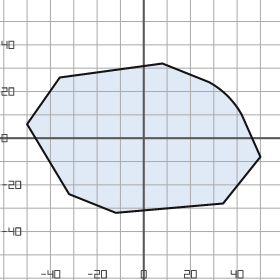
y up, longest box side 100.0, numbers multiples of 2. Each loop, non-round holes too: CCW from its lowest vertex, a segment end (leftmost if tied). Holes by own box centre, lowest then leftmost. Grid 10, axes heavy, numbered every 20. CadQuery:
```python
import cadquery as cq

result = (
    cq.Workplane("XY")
    .moveTo(-12.0, -32.0)
    .lineTo(34.0, -28.0)
    .lineTo(50.0, -8.0)
    .lineTo(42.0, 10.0)
    .threePointArc((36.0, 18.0), (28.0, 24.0))
    .lineTo(8.0, 32.0)
    .lineTo(-36.0, 26.0)
    .lineTo(-50.0, 6.0)
    .lineTo(-32.0, -24.0)
    .close()
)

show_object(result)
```